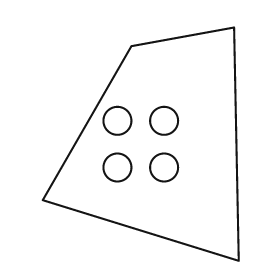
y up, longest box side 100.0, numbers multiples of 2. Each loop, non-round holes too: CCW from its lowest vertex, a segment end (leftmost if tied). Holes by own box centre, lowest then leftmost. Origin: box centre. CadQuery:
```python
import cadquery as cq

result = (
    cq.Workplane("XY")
    .moveTo(42.0, -50.0)
    .lineTo(40.0, 50.0)
    .lineTo(-4.0, 42.0)
    .lineTo(-42.0, -24.0)
    .close()
    .moveTo(-10.0, -10.0)
    .circle(6.0)
    .moveTo(10.0, -10.0)
    .circle(6.0)
    .moveTo(-10.0, 10.0)
    .circle(6.0)
    .moveTo(10.0, 10.0)
    .circle(6.0)
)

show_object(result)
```